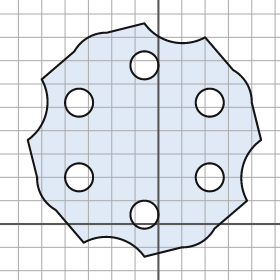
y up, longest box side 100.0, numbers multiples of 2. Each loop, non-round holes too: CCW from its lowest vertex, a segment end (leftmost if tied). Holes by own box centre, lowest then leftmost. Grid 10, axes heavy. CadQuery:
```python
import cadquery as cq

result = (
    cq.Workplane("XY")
    .moveTo(-6.0, -14.0)
    .lineTo(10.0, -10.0)
    .threePointArc((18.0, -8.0), (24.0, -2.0))
    .lineTo(38.0, 10.0)
    .threePointArc((36.0, 24.0), (44.0, 36.0))
    .lineTo(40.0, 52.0)
    .threePointArc((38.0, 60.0), (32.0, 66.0))
    .lineTo(20.0, 80.0)
    .threePointArc((6.0, 78.0), (-6.0, 86.0))
    .lineTo(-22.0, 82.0)
    .threePointArc((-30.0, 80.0), (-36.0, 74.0))
    .lineTo(-50.0, 62.0)
    .threePointArc((-48.0, 48.0), (-56.0, 36.0))
    .lineTo(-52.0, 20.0)
    .threePointArc((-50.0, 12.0), (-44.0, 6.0))
    .lineTo(-32.0, -8.0)
    .threePointArc((-18.0, -6.0), (-6.0, -14.0))
    .close()
    .moveTo(-6.0, 4.0)
    .circle(6.0)
    .moveTo(-34.0, 20.0)
    .circle(6.0)
    .moveTo(22.0, 20.0)
    .circle(6.0)
    .moveTo(-34.0, 52.0)
    .circle(6.0)
    .moveTo(22.0, 52.0)
    .circle(6.0)
    .moveTo(-6.0, 68.0)
    .circle(6.0)
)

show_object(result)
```